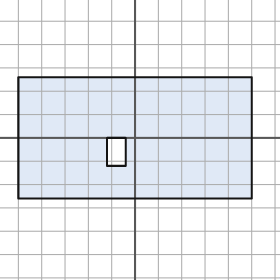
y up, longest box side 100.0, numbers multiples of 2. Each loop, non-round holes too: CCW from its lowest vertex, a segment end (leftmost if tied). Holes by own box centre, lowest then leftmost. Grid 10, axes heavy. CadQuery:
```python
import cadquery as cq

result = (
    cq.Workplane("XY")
    .moveTo(-50.0, -26.0)
    .lineTo(50.0, -26.0)
    .lineTo(50.0, 26.0)
    .lineTo(-50.0, 26.0)
    .close()
    .moveTo(-12.0, -12.0)
    .lineTo(-4.0, -12.0)
    .lineTo(-4.0, 0.0)
    .lineTo(-12.0, 0.0)
    .close()
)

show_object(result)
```